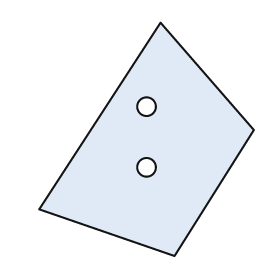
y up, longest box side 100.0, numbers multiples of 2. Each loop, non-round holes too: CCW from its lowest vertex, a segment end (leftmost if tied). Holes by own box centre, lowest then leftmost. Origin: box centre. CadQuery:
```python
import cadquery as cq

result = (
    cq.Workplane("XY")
    .moveTo(12.0, -50.0)
    .lineTo(46.0, 4.0)
    .lineTo(6.0, 50.0)
    .lineTo(-46.0, -30.0)
    .close()
    .moveTo(0.0, -12.0)
    .circle(4.0)
    .moveTo(0.0, 14.0)
    .circle(4.0)
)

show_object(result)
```